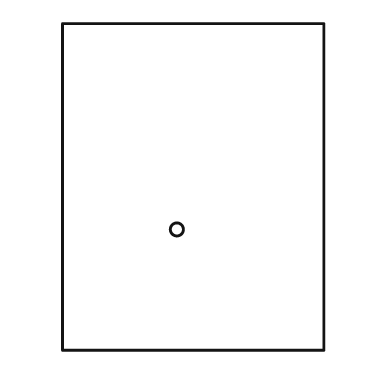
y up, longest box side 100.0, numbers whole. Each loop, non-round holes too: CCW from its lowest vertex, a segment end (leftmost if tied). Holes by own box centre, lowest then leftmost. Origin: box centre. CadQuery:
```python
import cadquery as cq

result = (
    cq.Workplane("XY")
    .moveTo(-40.0, -50.0)
    .lineTo(40.0, -50.0)
    .lineTo(40.0, 50.0)
    .lineTo(-40.0, 50.0)
    .close()
    .moveTo(-5.0, -13.0)
    .circle(2.0)
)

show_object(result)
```